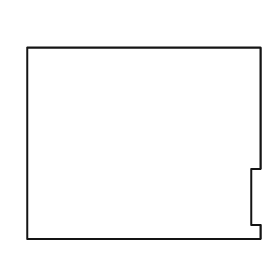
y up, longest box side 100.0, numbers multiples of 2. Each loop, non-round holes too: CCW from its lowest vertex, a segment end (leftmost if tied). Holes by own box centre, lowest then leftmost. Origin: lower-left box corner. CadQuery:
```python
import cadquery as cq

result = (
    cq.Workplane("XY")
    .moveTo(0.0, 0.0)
    .lineTo(100.0, 0.0)
    .lineTo(100.0, 6.0)
    .lineTo(96.0, 6.0)
    .lineTo(96.0, 30.0)
    .lineTo(100.0, 30.0)
    .lineTo(100.0, 82.0)
    .lineTo(0.0, 82.0)
    .close()
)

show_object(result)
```